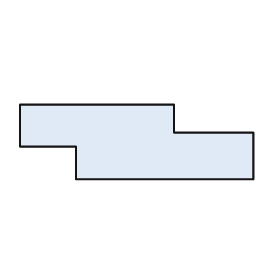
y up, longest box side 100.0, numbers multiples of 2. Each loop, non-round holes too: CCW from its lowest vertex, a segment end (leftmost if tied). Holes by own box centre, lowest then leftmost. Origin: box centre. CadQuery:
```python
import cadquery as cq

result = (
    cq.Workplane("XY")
    .moveTo(-26.0, -16.0)
    .lineTo(50.0, -16.0)
    .lineTo(50.0, 4.0)
    .lineTo(16.0, 4.0)
    .lineTo(16.0, 16.0)
    .lineTo(-50.0, 16.0)
    .lineTo(-50.0, -2.0)
    .lineTo(-26.0, -2.0)
    .close()
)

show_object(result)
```